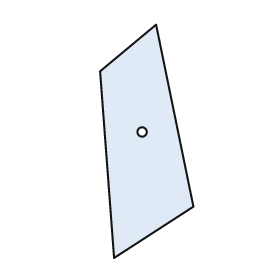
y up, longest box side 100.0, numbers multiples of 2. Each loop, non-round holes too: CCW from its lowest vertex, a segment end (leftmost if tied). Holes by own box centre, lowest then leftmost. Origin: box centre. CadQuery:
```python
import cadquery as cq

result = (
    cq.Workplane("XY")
    .moveTo(-14.0, -50.0)
    .lineTo(20.0, -28.0)
    .lineTo(4.0, 50.0)
    .lineTo(-20.0, 30.0)
    .close()
    .moveTo(-2.0, 4.0)
    .circle(2.0)
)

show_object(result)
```